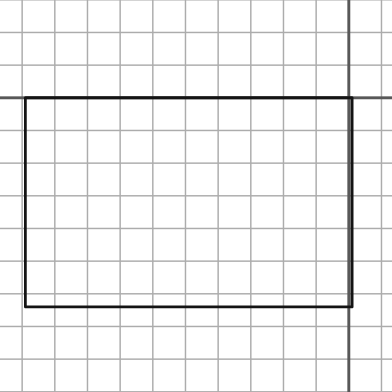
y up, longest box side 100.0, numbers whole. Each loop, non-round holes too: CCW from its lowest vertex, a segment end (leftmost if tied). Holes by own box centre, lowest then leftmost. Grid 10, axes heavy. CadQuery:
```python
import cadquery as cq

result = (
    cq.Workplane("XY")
    .moveTo(-99.0, -64.0)
    .lineTo(1.0, -64.0)
    .lineTo(1.0, 0.0)
    .lineTo(-99.0, 0.0)
    .close()
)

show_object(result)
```